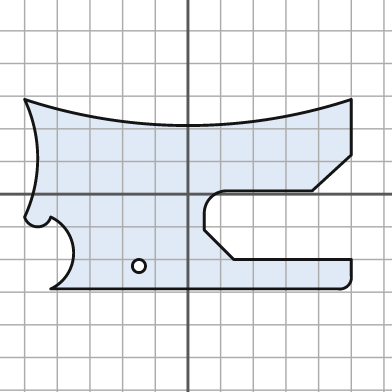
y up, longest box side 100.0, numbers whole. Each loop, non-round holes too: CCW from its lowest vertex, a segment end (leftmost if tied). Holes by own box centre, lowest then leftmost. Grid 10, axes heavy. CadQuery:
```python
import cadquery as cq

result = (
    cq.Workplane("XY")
    .moveTo(-42.0, -29.0)
    .lineTo(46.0, -29.0)
    .threePointArc((49.0, -28.0), (50.0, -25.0))
    .lineTo(50.0, -20.0)
    .lineTo(14.0, -20.0)
    .lineTo(5.0, -11.0)
    .lineTo(5.0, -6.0)
    .threePointArc((7.0, -1.0), (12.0, 1.0))
    .lineTo(38.0, 1.0)
    .lineTo(50.0, 12.0)
    .lineTo(50.0, 29.0)
    .threePointArc((0.0, 21.0), (-50.0, 29.0))
    .threePointArc((-46.0, 11.0), (-50.0, -7.0))
    .threePointArc((-46.0, -10.0), (-42.0, -7.0))
    .threePointArc((-35.0, -18.0), (-42.0, -29.0))
    .close()
    .moveTo(-15.0, -22.0)
    .circle(2.0)
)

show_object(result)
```